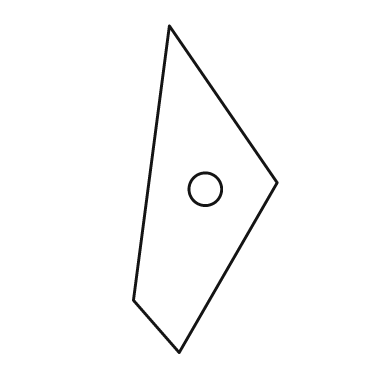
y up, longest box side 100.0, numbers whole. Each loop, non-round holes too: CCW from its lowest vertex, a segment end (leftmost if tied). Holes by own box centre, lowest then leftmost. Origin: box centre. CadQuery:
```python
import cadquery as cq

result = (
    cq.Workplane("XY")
    .moveTo(-8.0, -50.0)
    .lineTo(22.0, 2.0)
    .lineTo(-11.0, 50.0)
    .lineTo(-22.0, -34.0)
    .close()
    .moveTo(0.0, 0.0)
    .circle(5.0)
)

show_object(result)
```